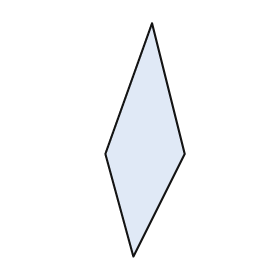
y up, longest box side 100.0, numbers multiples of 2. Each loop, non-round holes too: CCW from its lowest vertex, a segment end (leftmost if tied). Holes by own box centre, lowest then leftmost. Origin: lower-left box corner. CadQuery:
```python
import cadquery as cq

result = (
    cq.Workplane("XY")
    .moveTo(12.0, 0.0)
    .lineTo(34.0, 44.0)
    .lineTo(20.0, 100.0)
    .lineTo(0.0, 44.0)
    .close()
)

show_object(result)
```